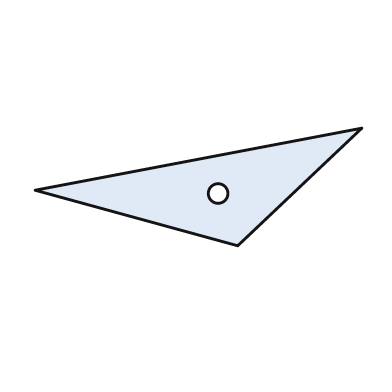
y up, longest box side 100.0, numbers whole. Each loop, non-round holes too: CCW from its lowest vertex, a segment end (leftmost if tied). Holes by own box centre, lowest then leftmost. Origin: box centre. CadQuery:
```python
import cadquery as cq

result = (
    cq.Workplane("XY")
    .moveTo(12.0, -18.0)
    .lineTo(50.0, 18.0)
    .lineTo(-50.0, -1.0)
    .close()
    .moveTo(6.0, -2.0)
    .circle(3.0)
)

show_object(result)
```